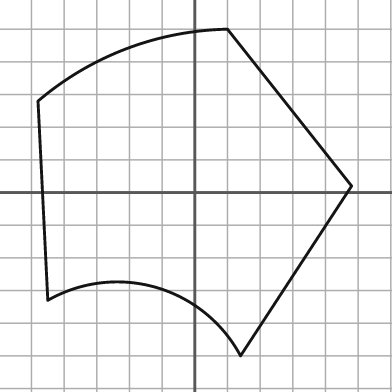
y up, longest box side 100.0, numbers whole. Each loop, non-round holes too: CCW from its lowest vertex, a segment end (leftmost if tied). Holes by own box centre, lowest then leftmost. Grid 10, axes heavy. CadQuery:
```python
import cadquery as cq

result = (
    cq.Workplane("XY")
    .moveTo(14.0, -50.0)
    .lineTo(48.0, 2.0)
    .lineTo(10.0, 50.0)
    .threePointArc((-21.0, 44.0), (-48.0, 28.0))
    .lineTo(-45.0, -33.0)
    .threePointArc((-12.0, -29.0), (14.0, -50.0))
    .close()
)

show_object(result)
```